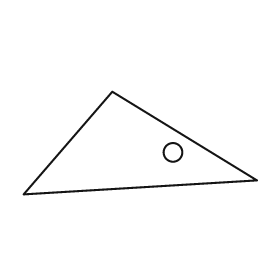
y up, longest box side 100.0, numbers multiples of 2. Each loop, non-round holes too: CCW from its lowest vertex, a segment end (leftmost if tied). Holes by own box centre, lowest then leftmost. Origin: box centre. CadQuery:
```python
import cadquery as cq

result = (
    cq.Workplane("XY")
    .moveTo(-50.0, -22.0)
    .lineTo(50.0, -16.0)
    .lineTo(-12.0, 22.0)
    .close()
    .moveTo(14.0, -4.0)
    .circle(4.0)
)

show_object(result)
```